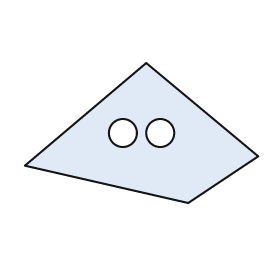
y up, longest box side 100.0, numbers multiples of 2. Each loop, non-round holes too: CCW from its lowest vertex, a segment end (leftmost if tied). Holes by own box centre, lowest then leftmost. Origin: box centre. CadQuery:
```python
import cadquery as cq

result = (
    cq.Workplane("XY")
    .moveTo(20.0, -30.0)
    .lineTo(50.0, -10.0)
    .lineTo(2.0, 30.0)
    .lineTo(-50.0, -14.0)
    .close()
    .moveTo(-8.0, 0.0)
    .circle(6.0)
    .moveTo(8.0, 0.0)
    .circle(6.0)
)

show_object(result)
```